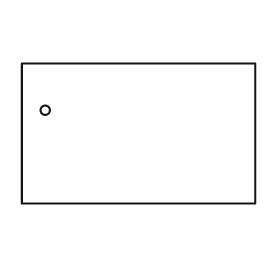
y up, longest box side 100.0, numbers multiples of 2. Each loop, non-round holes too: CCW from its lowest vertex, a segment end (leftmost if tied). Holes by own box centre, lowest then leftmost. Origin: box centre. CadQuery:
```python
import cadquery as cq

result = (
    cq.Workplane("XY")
    .moveTo(-50.0, -30.0)
    .lineTo(50.0, -30.0)
    .lineTo(50.0, 30.0)
    .lineTo(-50.0, 30.0)
    .close()
    .moveTo(-40.0, 10.0)
    .circle(2.0)
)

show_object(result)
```